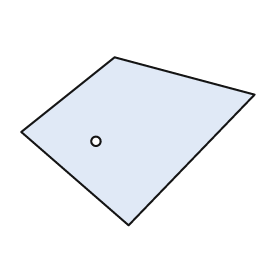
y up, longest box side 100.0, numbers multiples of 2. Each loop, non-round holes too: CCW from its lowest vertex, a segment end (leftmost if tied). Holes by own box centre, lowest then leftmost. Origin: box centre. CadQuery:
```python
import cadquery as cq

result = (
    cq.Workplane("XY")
    .moveTo(-4.0, -36.0)
    .lineTo(50.0, 20.0)
    .lineTo(-10.0, 36.0)
    .lineTo(-50.0, 4.0)
    .close()
    .moveTo(-18.0, 0.0)
    .circle(2.0)
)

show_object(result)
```